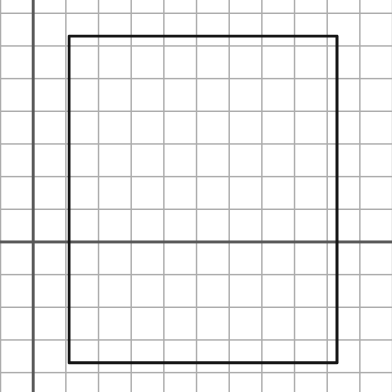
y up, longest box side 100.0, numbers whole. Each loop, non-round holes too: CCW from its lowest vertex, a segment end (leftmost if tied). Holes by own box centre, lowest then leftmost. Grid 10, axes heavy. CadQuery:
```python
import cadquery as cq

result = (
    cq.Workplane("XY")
    .moveTo(11.0, -37.0)
    .lineTo(93.0, -37.0)
    .lineTo(93.0, 63.0)
    .lineTo(11.0, 63.0)
    .close()
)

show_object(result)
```